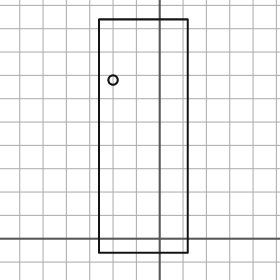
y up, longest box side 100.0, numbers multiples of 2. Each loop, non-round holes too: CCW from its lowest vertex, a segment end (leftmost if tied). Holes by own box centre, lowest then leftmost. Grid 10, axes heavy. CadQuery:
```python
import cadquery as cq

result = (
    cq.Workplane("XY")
    .moveTo(-26.0, -6.0)
    .lineTo(12.0, -6.0)
    .lineTo(12.0, 94.0)
    .lineTo(-26.0, 94.0)
    .close()
    .moveTo(-20.0, 68.0)
    .circle(2.0)
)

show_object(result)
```